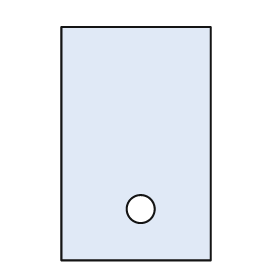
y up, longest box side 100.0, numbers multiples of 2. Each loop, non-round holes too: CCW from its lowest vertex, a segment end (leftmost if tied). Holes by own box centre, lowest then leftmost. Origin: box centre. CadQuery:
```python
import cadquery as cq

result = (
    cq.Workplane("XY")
    .moveTo(-32.0, -50.0)
    .lineTo(32.0, -50.0)
    .lineTo(32.0, 50.0)
    .lineTo(-32.0, 50.0)
    .close()
    .moveTo(2.0, -28.0)
    .circle(6.0)
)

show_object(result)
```